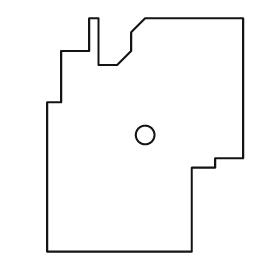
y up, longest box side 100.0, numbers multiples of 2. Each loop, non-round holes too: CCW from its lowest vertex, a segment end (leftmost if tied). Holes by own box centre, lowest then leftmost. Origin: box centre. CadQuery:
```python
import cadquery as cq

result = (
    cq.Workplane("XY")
    .moveTo(-42.0, -50.0)
    .lineTo(20.0, -50.0)
    .lineTo(20.0, -14.0)
    .lineTo(30.0, -14.0)
    .lineTo(30.0, -10.0)
    .lineTo(42.0, -10.0)
    .lineTo(42.0, 50.0)
    .lineTo(0.0, 50.0)
    .lineTo(-6.0, 44.0)
    .lineTo(-6.0, 36.0)
    .lineTo(-12.0, 30.0)
    .lineTo(-20.0, 30.0)
    .lineTo(-20.0, 50.0)
    .lineTo(-24.0, 50.0)
    .lineTo(-24.0, 36.0)
    .lineTo(-36.0, 36.0)
    .lineTo(-36.0, 14.0)
    .lineTo(-42.0, 14.0)
    .close()
    .moveTo(0.0, 0.0)
    .circle(4.0)
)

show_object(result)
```